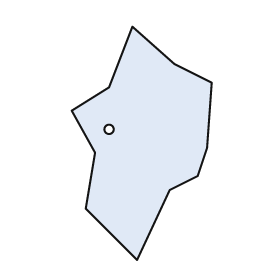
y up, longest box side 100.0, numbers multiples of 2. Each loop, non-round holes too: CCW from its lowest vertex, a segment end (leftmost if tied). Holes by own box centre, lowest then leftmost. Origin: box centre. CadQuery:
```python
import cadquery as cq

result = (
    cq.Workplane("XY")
    .moveTo(-2.0, -50.0)
    .lineTo(12.0, -20.0)
    .lineTo(24.0, -14.0)
    .lineTo(28.0, -2.0)
    .lineTo(30.0, 26.0)
    .lineTo(14.0, 34.0)
    .lineTo(-4.0, 50.0)
    .lineTo(-14.0, 24.0)
    .lineTo(-30.0, 14.0)
    .lineTo(-20.0, -4.0)
    .lineTo(-24.0, -28.0)
    .close()
    .moveTo(-14.0, 6.0)
    .circle(2.0)
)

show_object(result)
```